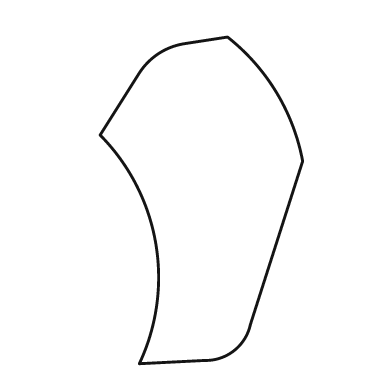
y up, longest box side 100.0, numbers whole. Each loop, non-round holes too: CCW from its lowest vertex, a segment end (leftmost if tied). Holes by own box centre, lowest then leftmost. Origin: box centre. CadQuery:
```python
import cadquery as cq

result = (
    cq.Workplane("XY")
    .moveTo(-19.0, -50.0)
    .lineTo(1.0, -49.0)
    .threePointArc((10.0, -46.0), (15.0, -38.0))
    .lineTo(31.0, 12.0)
    .threePointArc((23.0, 33.0), (8.0, 50.0))
    .lineTo(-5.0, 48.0)
    .threePointArc((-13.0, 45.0), (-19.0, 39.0))
    .lineTo(-31.0, 20.0)
    .threePointArc((-14.0, -13.0), (-19.0, -50.0))
    .close()
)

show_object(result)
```